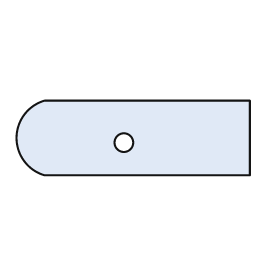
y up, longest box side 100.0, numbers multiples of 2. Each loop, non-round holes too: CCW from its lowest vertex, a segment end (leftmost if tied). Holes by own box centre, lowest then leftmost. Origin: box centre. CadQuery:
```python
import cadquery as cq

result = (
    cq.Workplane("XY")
    .moveTo(-38.0, -16.0)
    .lineTo(50.0, -16.0)
    .lineTo(50.0, 16.0)
    .lineTo(-38.0, 16.0)
    .threePointArc((-50.0, 0.0), (-38.0, -16.0))
    .close()
    .moveTo(-4.0, -2.0)
    .circle(4.0)
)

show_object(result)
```